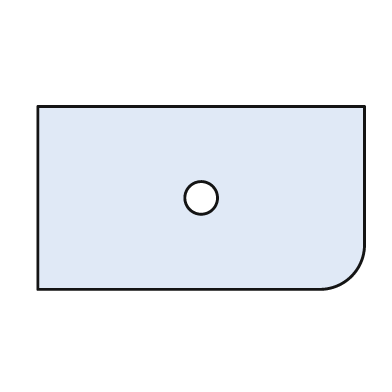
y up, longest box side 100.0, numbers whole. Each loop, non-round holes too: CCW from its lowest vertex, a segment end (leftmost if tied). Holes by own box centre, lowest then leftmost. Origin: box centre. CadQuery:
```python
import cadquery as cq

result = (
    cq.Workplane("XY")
    .moveTo(-50.0, -28.0)
    .lineTo(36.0, -28.0)
    .threePointArc((46.0, -24.0), (50.0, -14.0))
    .lineTo(50.0, 28.0)
    .lineTo(-50.0, 28.0)
    .close()
    .moveTo(0.0, 0.0)
    .circle(5.0)
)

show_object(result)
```